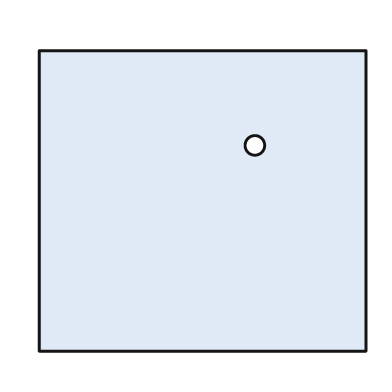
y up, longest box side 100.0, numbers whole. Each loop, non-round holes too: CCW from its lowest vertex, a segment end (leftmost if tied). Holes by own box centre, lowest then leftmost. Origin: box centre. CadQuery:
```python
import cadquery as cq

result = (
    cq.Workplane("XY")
    .moveTo(-50.0, -46.0)
    .lineTo(50.0, -46.0)
    .lineTo(50.0, 46.0)
    .lineTo(-50.0, 46.0)
    .close()
    .moveTo(16.0, 17.0)
    .circle(3.0)
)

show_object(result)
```